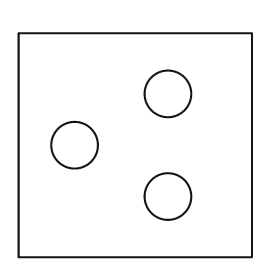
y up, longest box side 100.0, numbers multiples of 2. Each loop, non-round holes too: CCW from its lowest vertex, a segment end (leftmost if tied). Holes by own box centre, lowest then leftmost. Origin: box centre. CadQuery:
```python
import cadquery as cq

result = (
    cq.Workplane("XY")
    .moveTo(-50.0, -48.0)
    .lineTo(50.0, -48.0)
    .lineTo(50.0, 48.0)
    .lineTo(-50.0, 48.0)
    .close()
    .moveTo(14.0, -22.0)
    .circle(10.0)
    .moveTo(-26.0, 0.0)
    .circle(10.0)
    .moveTo(14.0, 22.0)
    .circle(10.0)
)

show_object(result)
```